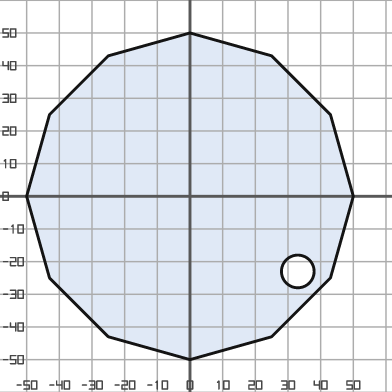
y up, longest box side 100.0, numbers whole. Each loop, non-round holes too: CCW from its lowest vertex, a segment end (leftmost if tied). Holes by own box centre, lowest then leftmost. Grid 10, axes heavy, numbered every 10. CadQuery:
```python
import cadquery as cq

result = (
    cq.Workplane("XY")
    .moveTo(0.0, -50.0)
    .lineTo(25.0, -43.0)
    .lineTo(43.0, -25.0)
    .lineTo(50.0, 0.0)
    .lineTo(43.0, 25.0)
    .lineTo(25.0, 43.0)
    .lineTo(0.0, 50.0)
    .lineTo(-25.0, 43.0)
    .lineTo(-43.0, 25.0)
    .lineTo(-50.0, 0.0)
    .lineTo(-43.0, -25.0)
    .lineTo(-25.0, -43.0)
    .close()
    .moveTo(33.0, -23.0)
    .circle(5.0)
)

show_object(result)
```